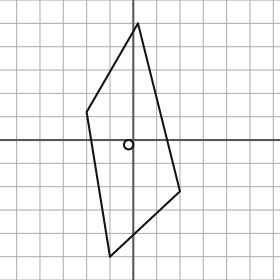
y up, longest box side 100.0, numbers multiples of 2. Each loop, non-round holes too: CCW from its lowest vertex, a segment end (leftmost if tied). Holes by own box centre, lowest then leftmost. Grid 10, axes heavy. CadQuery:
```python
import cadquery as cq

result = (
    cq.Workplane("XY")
    .moveTo(-10.0, -50.0)
    .lineTo(20.0, -22.0)
    .lineTo(2.0, 50.0)
    .lineTo(-20.0, 12.0)
    .close()
    .moveTo(-2.0, -2.0)
    .circle(2.0)
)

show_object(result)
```